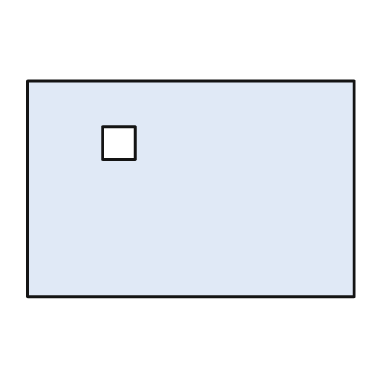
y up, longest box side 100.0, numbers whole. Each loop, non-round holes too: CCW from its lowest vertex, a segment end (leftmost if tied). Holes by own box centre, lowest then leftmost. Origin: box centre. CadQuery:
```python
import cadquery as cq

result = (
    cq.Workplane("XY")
    .moveTo(-50.0, -33.0)
    .lineTo(50.0, -33.0)
    .lineTo(50.0, 33.0)
    .lineTo(-50.0, 33.0)
    .close()
    .moveTo(-27.0, 9.0)
    .lineTo(-17.0, 9.0)
    .lineTo(-17.0, 19.0)
    .lineTo(-27.0, 19.0)
    .close()
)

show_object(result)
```